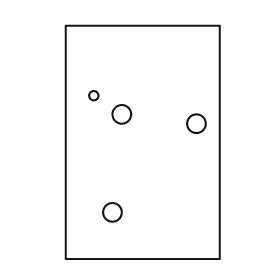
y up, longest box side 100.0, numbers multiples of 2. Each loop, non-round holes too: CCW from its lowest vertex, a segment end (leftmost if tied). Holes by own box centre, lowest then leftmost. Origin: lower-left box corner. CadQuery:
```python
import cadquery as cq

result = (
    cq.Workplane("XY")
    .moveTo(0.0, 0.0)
    .lineTo(66.0, 0.0)
    .lineTo(66.0, 100.0)
    .lineTo(0.0, 100.0)
    .close()
    .moveTo(20.0, 20.0)
    .circle(4.0)
    .moveTo(56.0, 58.0)
    .circle(4.0)
    .moveTo(24.0, 62.0)
    .circle(4.0)
    .moveTo(12.0, 70.0)
    .circle(2.0)
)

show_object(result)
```